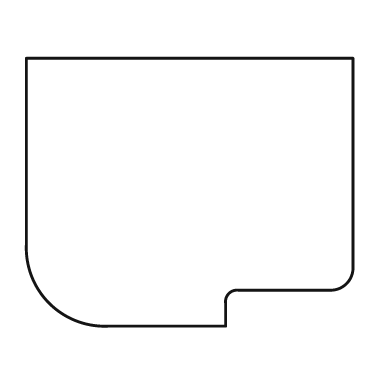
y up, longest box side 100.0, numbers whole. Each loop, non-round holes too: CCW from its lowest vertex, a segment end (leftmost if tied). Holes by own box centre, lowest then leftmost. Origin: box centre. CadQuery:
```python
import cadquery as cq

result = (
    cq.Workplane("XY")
    .moveTo(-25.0, -41.0)
    .lineTo(11.0, -41.0)
    .lineTo(11.0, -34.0)
    .threePointArc((12.0, -31.0), (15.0, -30.0))
    .lineTo(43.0, -30.0)
    .threePointArc((48.0, -28.0), (50.0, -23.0))
    .lineTo(50.0, 41.0)
    .lineTo(-50.0, 41.0)
    .lineTo(-50.0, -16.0)
    .threePointArc((-43.0, -34.0), (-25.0, -41.0))
    .close()
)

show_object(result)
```